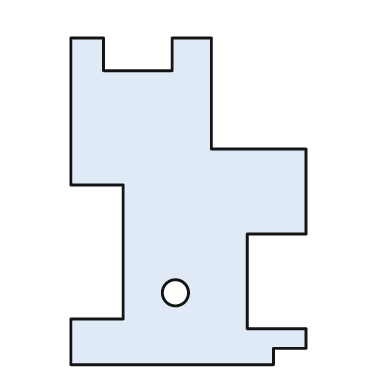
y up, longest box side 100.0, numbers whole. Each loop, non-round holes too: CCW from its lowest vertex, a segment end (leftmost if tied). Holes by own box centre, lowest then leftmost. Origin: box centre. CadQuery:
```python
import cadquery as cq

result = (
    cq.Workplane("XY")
    .moveTo(-36.0, -50.0)
    .lineTo(26.0, -50.0)
    .lineTo(26.0, -45.0)
    .lineTo(36.0, -45.0)
    .lineTo(36.0, -39.0)
    .lineTo(18.0, -39.0)
    .lineTo(18.0, -10.0)
    .lineTo(36.0, -10.0)
    .lineTo(36.0, 16.0)
    .lineTo(7.0, 16.0)
    .lineTo(7.0, 50.0)
    .lineTo(-5.0, 50.0)
    .lineTo(-5.0, 40.0)
    .lineTo(-26.0, 40.0)
    .lineTo(-26.0, 50.0)
    .lineTo(-36.0, 50.0)
    .lineTo(-36.0, 5.0)
    .lineTo(-20.0, 5.0)
    .lineTo(-20.0, -36.0)
    .lineTo(-36.0, -36.0)
    .close()
    .moveTo(-4.0, -28.0)
    .circle(4.0)
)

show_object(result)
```